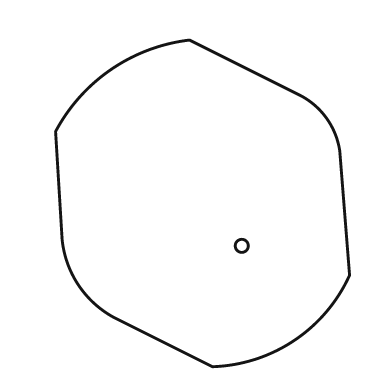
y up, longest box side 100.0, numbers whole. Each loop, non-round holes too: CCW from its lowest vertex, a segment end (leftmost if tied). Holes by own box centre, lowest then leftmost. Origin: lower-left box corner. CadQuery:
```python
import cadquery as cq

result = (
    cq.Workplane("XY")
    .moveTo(48.0, 0.0)
    .threePointArc((73.0, 8.0), (90.0, 28.0))
    .lineTo(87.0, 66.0)
    .threePointArc((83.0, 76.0), (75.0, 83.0))
    .lineTo(41.0, 100.0)
    .threePointArc((17.0, 91.0), (0.0, 72.0))
    .lineTo(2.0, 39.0)
    .threePointArc((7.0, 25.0), (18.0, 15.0))
    .close()
    .moveTo(57.0, 37.0)
    .circle(2.0)
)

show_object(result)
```